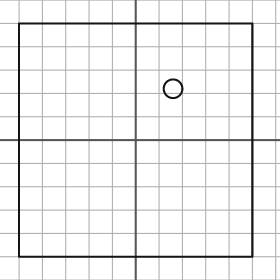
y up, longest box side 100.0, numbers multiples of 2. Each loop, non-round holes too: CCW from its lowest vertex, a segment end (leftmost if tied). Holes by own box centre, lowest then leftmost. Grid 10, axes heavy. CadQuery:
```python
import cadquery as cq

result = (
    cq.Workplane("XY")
    .moveTo(-50.0, -50.0)
    .lineTo(50.0, -50.0)
    .lineTo(50.0, 50.0)
    .lineTo(-50.0, 50.0)
    .close()
    .moveTo(16.0, 22.0)
    .circle(4.0)
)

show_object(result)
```